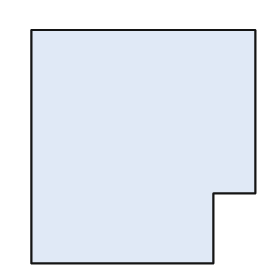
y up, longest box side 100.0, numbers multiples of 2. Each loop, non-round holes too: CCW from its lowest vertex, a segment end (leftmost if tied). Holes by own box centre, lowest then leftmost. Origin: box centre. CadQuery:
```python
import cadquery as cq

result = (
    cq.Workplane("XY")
    .moveTo(-48.0, -50.0)
    .lineTo(30.0, -50.0)
    .lineTo(30.0, -20.0)
    .lineTo(48.0, -20.0)
    .lineTo(48.0, 50.0)
    .lineTo(-48.0, 50.0)
    .close()
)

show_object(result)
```